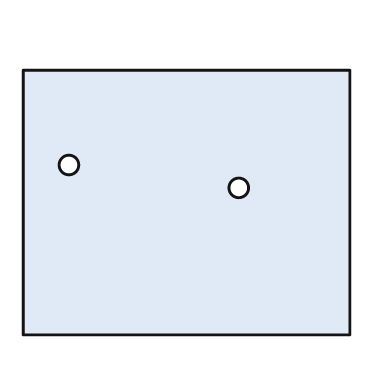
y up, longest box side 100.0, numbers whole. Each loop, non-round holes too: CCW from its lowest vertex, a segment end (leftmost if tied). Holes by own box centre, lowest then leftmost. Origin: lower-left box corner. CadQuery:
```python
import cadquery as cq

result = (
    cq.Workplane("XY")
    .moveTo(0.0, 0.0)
    .lineTo(100.0, 0.0)
    .lineTo(100.0, 81.0)
    .lineTo(0.0, 81.0)
    .close()
    .moveTo(66.0, 45.0)
    .circle(3.0)
    .moveTo(14.0, 52.0)
    .circle(3.0)
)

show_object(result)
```